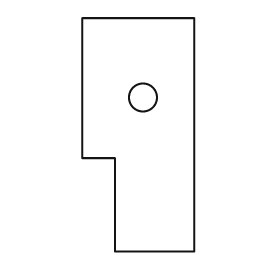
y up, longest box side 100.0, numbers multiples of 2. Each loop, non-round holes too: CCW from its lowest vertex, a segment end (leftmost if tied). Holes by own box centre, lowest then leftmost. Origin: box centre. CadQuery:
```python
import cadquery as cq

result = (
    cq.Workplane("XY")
    .moveTo(-10.0, -50.0)
    .lineTo(24.0, -50.0)
    .lineTo(24.0, 50.0)
    .lineTo(-24.0, 50.0)
    .lineTo(-24.0, -10.0)
    .lineTo(-10.0, -10.0)
    .close()
    .moveTo(2.0, 16.0)
    .circle(6.0)
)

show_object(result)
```